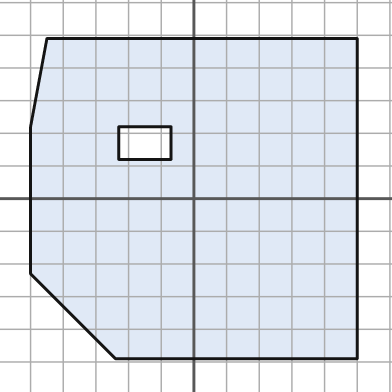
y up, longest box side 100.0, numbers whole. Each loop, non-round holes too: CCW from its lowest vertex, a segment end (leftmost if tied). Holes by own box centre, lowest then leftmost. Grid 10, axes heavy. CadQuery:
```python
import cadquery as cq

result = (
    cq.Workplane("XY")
    .moveTo(-24.0, -49.0)
    .lineTo(50.0, -49.0)
    .lineTo(50.0, 49.0)
    .lineTo(-45.0, 49.0)
    .lineTo(-50.0, 22.0)
    .lineTo(-50.0, -23.0)
    .close()
    .moveTo(-23.0, 12.0)
    .lineTo(-7.0, 12.0)
    .lineTo(-7.0, 22.0)
    .lineTo(-23.0, 22.0)
    .close()
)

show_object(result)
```